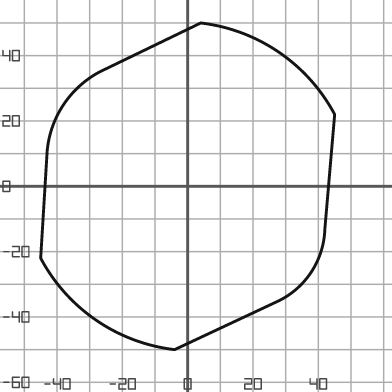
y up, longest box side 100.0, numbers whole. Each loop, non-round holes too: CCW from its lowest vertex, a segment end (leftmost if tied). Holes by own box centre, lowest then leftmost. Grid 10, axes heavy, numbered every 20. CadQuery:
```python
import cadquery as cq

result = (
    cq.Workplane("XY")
    .moveTo(-4.0, -50.0)
    .lineTo(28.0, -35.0)
    .threePointArc((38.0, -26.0), (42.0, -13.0))
    .lineTo(45.0, 22.0)
    .threePointArc((28.0, 41.0), (4.0, 50.0))
    .lineTo(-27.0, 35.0)
    .threePointArc((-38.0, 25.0), (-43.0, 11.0))
    .lineTo(-45.0, -22.0)
    .threePointArc((-28.0, -41.0), (-4.0, -50.0))
    .close()
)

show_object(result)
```